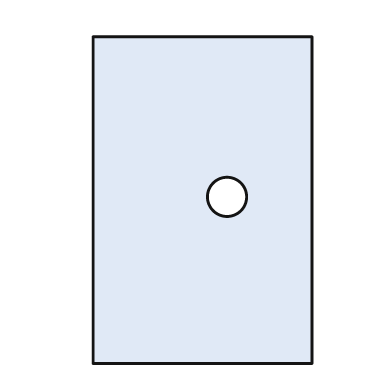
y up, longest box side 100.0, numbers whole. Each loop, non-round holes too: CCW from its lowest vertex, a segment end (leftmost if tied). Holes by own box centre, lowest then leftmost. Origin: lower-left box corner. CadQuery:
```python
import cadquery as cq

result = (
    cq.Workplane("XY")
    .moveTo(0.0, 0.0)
    .lineTo(67.0, 0.0)
    .lineTo(67.0, 100.0)
    .lineTo(0.0, 100.0)
    .close()
    .moveTo(41.0, 51.0)
    .circle(6.0)
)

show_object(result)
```